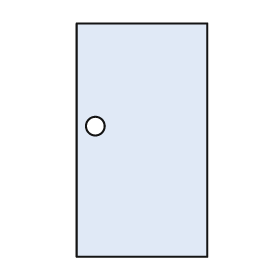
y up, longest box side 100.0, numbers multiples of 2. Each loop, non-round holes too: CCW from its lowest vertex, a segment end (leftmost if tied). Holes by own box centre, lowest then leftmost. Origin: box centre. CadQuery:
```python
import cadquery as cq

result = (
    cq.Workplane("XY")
    .moveTo(-28.0, -50.0)
    .lineTo(28.0, -50.0)
    .lineTo(28.0, 50.0)
    .lineTo(-28.0, 50.0)
    .close()
    .moveTo(-20.0, 6.0)
    .circle(4.0)
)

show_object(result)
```